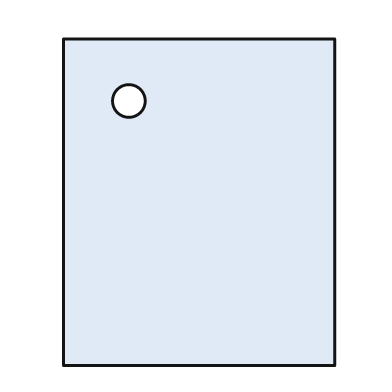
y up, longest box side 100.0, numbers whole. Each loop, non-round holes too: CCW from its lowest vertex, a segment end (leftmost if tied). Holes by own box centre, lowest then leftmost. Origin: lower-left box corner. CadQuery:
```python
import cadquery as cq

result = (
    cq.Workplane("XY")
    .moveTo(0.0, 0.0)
    .lineTo(83.0, 0.0)
    .lineTo(83.0, 100.0)
    .lineTo(0.0, 100.0)
    .close()
    .moveTo(20.0, 81.0)
    .circle(5.0)
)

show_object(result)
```